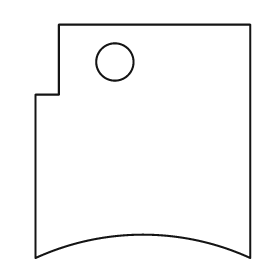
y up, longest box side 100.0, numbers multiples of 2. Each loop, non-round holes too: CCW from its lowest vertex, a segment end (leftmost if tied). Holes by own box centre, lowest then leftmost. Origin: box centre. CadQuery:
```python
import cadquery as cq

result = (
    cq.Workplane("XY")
    .moveTo(-46.0, -50.0)
    .threePointArc((0.0, -40.0), (46.0, -50.0))
    .lineTo(46.0, 50.0)
    .lineTo(-36.0, 50.0)
    .lineTo(-36.0, 20.0)
    .lineTo(-46.0, 20.0)
    .close()
    .moveTo(-12.0, 34.0)
    .circle(8.0)
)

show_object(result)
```